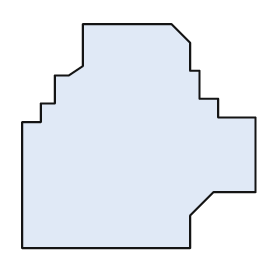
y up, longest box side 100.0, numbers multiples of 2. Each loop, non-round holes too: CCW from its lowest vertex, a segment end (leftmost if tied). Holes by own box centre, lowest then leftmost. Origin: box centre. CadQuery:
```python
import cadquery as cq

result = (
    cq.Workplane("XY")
    .moveTo(-50.0, -48.0)
    .lineTo(22.0, -48.0)
    .lineTo(22.0, -34.0)
    .lineTo(32.0, -24.0)
    .lineTo(50.0, -24.0)
    .lineTo(50.0, 8.0)
    .lineTo(34.0, 8.0)
    .lineTo(34.0, 16.0)
    .lineTo(26.0, 16.0)
    .lineTo(26.0, 28.0)
    .lineTo(22.0, 28.0)
    .lineTo(22.0, 40.0)
    .lineTo(14.0, 48.0)
    .lineTo(-24.0, 48.0)
    .lineTo(-24.0, 30.0)
    .lineTo(-30.0, 26.0)
    .lineTo(-36.0, 26.0)
    .lineTo(-36.0, 14.0)
    .lineTo(-42.0, 14.0)
    .lineTo(-42.0, 6.0)
    .lineTo(-50.0, 6.0)
    .close()
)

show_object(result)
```